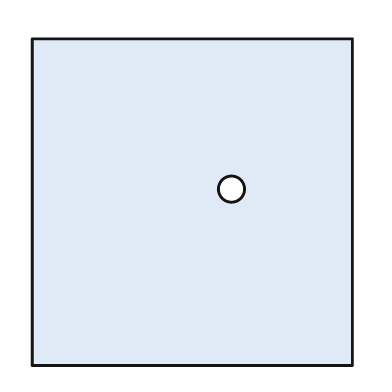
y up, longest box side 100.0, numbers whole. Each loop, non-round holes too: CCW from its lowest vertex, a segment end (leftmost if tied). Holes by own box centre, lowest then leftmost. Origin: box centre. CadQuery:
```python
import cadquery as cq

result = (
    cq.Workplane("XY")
    .moveTo(-49.0, -50.0)
    .lineTo(49.0, -50.0)
    .lineTo(49.0, 50.0)
    .lineTo(-49.0, 50.0)
    .close()
    .moveTo(12.0, 4.0)
    .circle(4.0)
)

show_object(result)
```